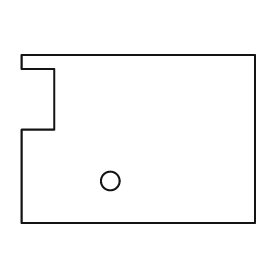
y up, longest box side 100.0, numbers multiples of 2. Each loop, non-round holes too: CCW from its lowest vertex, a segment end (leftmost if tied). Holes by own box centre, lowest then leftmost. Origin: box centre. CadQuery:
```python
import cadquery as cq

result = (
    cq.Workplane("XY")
    .moveTo(-50.0, -36.0)
    .lineTo(50.0, -36.0)
    .lineTo(50.0, 36.0)
    .lineTo(-50.0, 36.0)
    .lineTo(-50.0, 30.0)
    .lineTo(-36.0, 30.0)
    .lineTo(-36.0, 4.0)
    .lineTo(-50.0, 4.0)
    .close()
    .moveTo(-12.0, -18.0)
    .circle(4.0)
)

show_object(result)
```